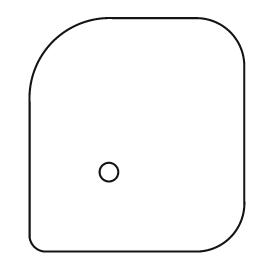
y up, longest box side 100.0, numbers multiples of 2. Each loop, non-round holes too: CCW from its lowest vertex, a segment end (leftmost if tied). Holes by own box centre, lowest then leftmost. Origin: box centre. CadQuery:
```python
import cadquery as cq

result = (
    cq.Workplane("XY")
    .moveTo(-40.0, -50.0)
    .lineTo(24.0, -50.0)
    .threePointArc((40.0, -44.0), (46.0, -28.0))
    .lineTo(46.0, 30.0)
    .threePointArc((40.0, 44.0), (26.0, 50.0))
    .lineTo(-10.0, 50.0)
    .threePointArc((-36.0, 40.0), (-46.0, 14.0))
    .lineTo(-46.0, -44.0)
    .threePointArc((-44.0, -48.0), (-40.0, -50.0))
    .close()
    .moveTo(-12.0, -16.0)
    .circle(4.0)
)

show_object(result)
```